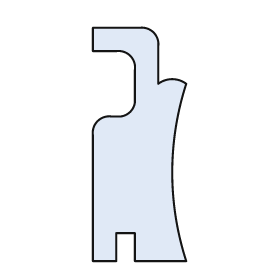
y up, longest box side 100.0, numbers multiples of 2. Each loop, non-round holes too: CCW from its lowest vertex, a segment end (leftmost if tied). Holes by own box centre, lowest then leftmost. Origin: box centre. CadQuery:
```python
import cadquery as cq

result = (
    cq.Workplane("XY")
    .moveTo(-20.0, -50.0)
    .lineTo(-10.0, -50.0)
    .lineTo(-10.0, -38.0)
    .lineTo(-2.0, -38.0)
    .lineTo(-2.0, -50.0)
    .lineTo(20.0, -50.0)
    .threePointArc((14.0, -12.0), (20.0, 26.0))
    .threePointArc((14.0, 28.0), (8.0, 26.0))
    .lineTo(8.0, 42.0)
    .threePointArc((6.0, 48.0), (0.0, 50.0))
    .lineTo(-20.0, 50.0)
    .lineTo(-20.0, 40.0)
    .lineTo(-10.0, 40.0)
    .threePointArc((-4.0, 38.0), (-2.0, 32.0))
    .lineTo(-2.0, 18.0)
    .threePointArc((-4.0, 14.0), (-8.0, 12.0))
    .lineTo(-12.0, 12.0)
    .threePointArc((-18.0, 10.0), (-20.0, 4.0))
    .close()
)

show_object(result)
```